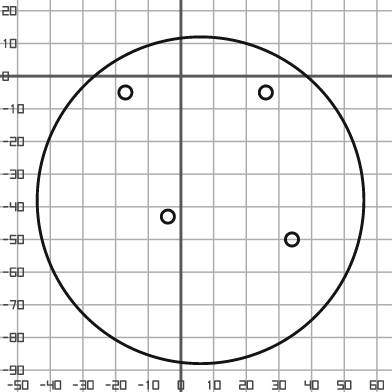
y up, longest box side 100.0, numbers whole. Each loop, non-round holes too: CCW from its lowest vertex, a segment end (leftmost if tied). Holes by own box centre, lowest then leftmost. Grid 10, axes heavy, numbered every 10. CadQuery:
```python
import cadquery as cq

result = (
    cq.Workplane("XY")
    .moveTo(6.0, -38.0)
    .circle(50.0)
    .moveTo(34.0, -50.0)
    .circle(2.0)
    .moveTo(-4.0, -43.0)
    .circle(2.0)
    .moveTo(-17.0, -5.0)
    .circle(2.0)
    .moveTo(26.0, -5.0)
    .circle(2.0)
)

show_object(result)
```